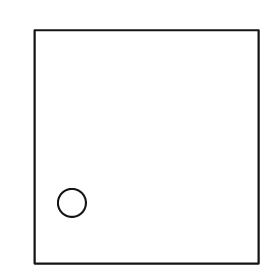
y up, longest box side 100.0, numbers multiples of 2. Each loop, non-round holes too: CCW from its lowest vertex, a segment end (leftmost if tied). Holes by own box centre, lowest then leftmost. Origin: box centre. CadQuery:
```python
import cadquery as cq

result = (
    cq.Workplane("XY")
    .moveTo(-48.0, -50.0)
    .lineTo(48.0, -50.0)
    .lineTo(48.0, 50.0)
    .lineTo(-48.0, 50.0)
    .close()
    .moveTo(-32.0, -24.0)
    .circle(6.0)
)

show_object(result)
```